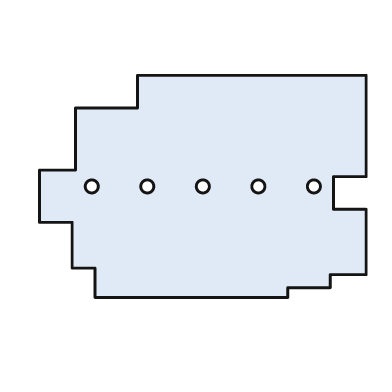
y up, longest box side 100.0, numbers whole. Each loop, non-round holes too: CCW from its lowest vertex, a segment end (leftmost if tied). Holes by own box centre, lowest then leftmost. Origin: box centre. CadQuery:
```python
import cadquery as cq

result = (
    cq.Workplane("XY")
    .moveTo(-33.0, -34.0)
    .lineTo(26.0, -34.0)
    .lineTo(26.0, -31.0)
    .lineTo(39.0, -31.0)
    .lineTo(39.0, -27.0)
    .lineTo(50.0, -27.0)
    .lineTo(50.0, -7.0)
    .lineTo(40.0, -7.0)
    .lineTo(40.0, 3.0)
    .lineTo(50.0, 3.0)
    .lineTo(50.0, 34.0)
    .lineTo(-20.0, 34.0)
    .lineTo(-20.0, 24.0)
    .lineTo(-39.0, 24.0)
    .lineTo(-39.0, 5.0)
    .lineTo(-50.0, 5.0)
    .lineTo(-50.0, -11.0)
    .lineTo(-40.0, -11.0)
    .lineTo(-40.0, -25.0)
    .lineTo(-33.0, -25.0)
    .close()
    .moveTo(-34.0, 0.0)
    .circle(2.0)
    .moveTo(-17.0, 0.0)
    .circle(2.0)
    .moveTo(0.0, 0.0)
    .circle(2.0)
    .moveTo(17.0, 0.0)
    .circle(2.0)
    .moveTo(34.0, 0.0)
    .circle(2.0)
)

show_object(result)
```